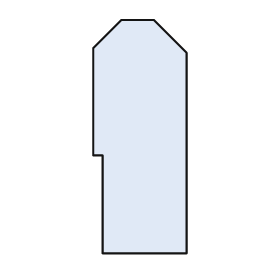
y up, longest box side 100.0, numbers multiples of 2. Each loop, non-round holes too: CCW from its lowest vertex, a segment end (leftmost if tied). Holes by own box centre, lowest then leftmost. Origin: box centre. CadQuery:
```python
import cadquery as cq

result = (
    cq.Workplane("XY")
    .moveTo(-16.0, -50.0)
    .lineTo(20.0, -50.0)
    .lineTo(20.0, 36.0)
    .lineTo(6.0, 50.0)
    .lineTo(-8.0, 50.0)
    .lineTo(-20.0, 38.0)
    .lineTo(-20.0, -8.0)
    .lineTo(-16.0, -8.0)
    .close()
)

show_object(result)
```